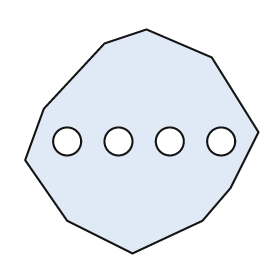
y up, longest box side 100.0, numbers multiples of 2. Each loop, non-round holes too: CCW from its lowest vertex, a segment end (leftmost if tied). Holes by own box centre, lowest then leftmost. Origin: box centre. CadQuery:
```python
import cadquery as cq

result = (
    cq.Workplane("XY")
    .moveTo(-4.0, -48.0)
    .lineTo(26.0, -34.0)
    .lineTo(38.0, -20.0)
    .lineTo(50.0, 4.0)
    .lineTo(30.0, 36.0)
    .lineTo(2.0, 48.0)
    .lineTo(-16.0, 42.0)
    .lineTo(-42.0, 14.0)
    .lineTo(-50.0, -8.0)
    .lineTo(-32.0, -34.0)
    .close()
    .moveTo(-32.0, 0.0)
    .circle(6.0)
    .moveTo(-10.0, 0.0)
    .circle(6.0)
    .moveTo(12.0, 0.0)
    .circle(6.0)
    .moveTo(34.0, 0.0)
    .circle(6.0)
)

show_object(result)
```